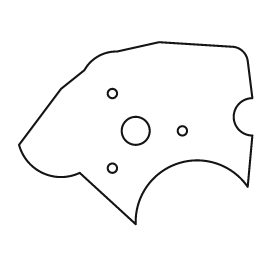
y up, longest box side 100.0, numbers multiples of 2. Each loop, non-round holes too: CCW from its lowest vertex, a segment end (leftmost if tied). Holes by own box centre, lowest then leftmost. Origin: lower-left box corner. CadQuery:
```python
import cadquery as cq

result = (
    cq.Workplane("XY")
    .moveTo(50.0, 0.0)
    .threePointArc((68.0, 26.0), (98.0, 16.0))
    .lineTo(100.0, 38.0)
    .threePointArc((92.0, 46.0), (100.0, 54.0))
    .lineTo(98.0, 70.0)
    .threePointArc((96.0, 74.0), (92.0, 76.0))
    .lineTo(60.0, 78.0)
    .lineTo(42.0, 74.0)
    .threePointArc((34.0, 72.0), (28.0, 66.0))
    .lineTo(18.0, 58.0)
    .lineTo(0.0, 34.0)
    .threePointArc((10.0, 22.0), (26.0, 22.0))
    .close()
    .moveTo(40.0, 24.0)
    .circle(2.0)
    .moveTo(50.0, 40.0)
    .circle(6.0)
    .moveTo(70.0, 40.0)
    .circle(2.0)
    .moveTo(40.0, 56.0)
    .circle(2.0)
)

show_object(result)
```